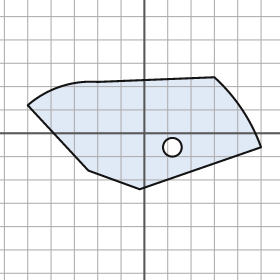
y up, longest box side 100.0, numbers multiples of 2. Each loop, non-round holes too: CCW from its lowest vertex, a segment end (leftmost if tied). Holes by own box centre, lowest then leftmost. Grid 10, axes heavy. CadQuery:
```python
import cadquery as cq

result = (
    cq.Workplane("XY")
    .moveTo(-2.0, -24.0)
    .lineTo(50.0, -6.0)
    .threePointArc((42.0, 10.0), (30.0, 24.0))
    .lineTo(-20.0, 22.0)
    .threePointArc((-36.0, 20.0), (-50.0, 12.0))
    .lineTo(-24.0, -16.0)
    .close()
    .moveTo(12.0, -6.0)
    .circle(4.0)
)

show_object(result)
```